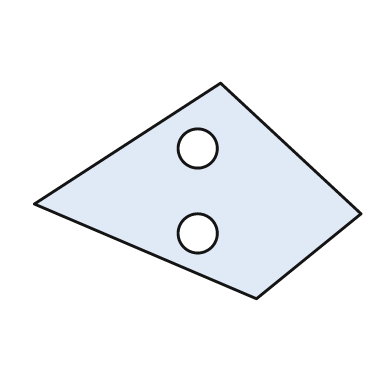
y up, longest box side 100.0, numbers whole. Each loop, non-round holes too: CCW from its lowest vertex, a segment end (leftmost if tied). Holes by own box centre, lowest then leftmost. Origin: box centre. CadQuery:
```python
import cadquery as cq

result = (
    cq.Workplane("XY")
    .moveTo(18.0, -33.0)
    .lineTo(50.0, -7.0)
    .lineTo(7.0, 33.0)
    .lineTo(-50.0, -4.0)
    .close()
    .moveTo(0.0, -13.0)
    .circle(6.0)
    .moveTo(0.0, 13.0)
    .circle(6.0)
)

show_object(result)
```